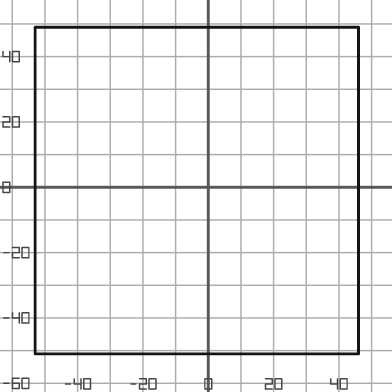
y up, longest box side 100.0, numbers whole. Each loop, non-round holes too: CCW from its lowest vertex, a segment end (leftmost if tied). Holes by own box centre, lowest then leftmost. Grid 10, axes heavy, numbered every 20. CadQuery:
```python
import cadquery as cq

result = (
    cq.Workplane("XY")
    .moveTo(-53.0, -51.0)
    .lineTo(46.0, -51.0)
    .lineTo(46.0, 49.0)
    .lineTo(-53.0, 49.0)
    .close()
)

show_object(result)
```